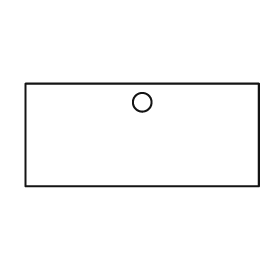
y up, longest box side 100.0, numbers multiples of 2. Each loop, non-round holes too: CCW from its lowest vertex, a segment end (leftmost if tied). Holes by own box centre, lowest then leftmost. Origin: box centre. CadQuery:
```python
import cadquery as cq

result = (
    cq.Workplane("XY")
    .moveTo(-50.0, -22.0)
    .lineTo(50.0, -22.0)
    .lineTo(50.0, 22.0)
    .lineTo(-50.0, 22.0)
    .close()
    .moveTo(0.0, 14.0)
    .circle(4.0)
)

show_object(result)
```